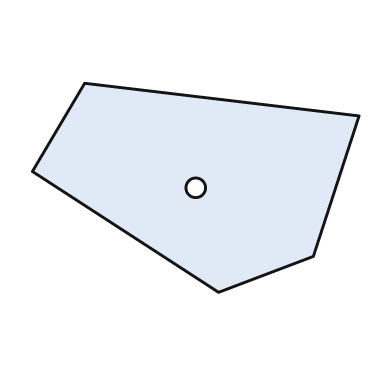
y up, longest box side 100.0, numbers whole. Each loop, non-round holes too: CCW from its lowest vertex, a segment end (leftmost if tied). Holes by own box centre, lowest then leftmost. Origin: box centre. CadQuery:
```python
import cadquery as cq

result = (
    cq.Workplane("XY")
    .moveTo(7.0, -32.0)
    .lineTo(36.0, -21.0)
    .lineTo(50.0, 22.0)
    .lineTo(-34.0, 32.0)
    .lineTo(-50.0, 5.0)
    .close()
    .moveTo(0.0, 0.0)
    .circle(3.0)
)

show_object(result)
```